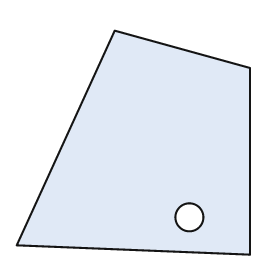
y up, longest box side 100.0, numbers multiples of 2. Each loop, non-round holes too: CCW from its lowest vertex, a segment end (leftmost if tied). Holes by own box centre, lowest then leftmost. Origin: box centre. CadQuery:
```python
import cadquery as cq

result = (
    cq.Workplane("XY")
    .moveTo(50.0, -48.0)
    .lineTo(50.0, 32.0)
    .lineTo(-8.0, 48.0)
    .lineTo(-50.0, -44.0)
    .close()
    .moveTo(24.0, -32.0)
    .circle(6.0)
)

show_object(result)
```